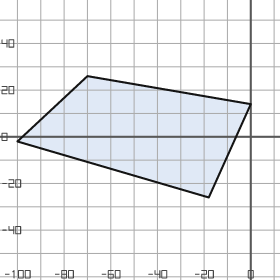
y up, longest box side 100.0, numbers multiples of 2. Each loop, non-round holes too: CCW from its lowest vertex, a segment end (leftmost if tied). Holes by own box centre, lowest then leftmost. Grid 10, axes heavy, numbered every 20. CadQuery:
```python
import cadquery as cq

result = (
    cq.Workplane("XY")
    .moveTo(-18.0, -26.0)
    .lineTo(0.0, 14.0)
    .lineTo(-70.0, 26.0)
    .lineTo(-100.0, -2.0)
    .close()
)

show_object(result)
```